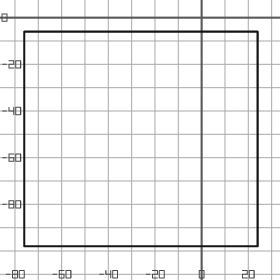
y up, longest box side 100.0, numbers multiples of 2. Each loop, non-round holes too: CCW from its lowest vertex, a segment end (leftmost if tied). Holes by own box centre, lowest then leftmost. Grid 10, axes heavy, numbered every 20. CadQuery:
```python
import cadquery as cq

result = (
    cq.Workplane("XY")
    .moveTo(-76.0, -98.0)
    .lineTo(24.0, -98.0)
    .lineTo(24.0, -6.0)
    .lineTo(-76.0, -6.0)
    .close()
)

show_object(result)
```